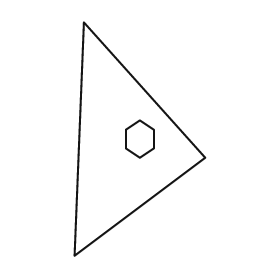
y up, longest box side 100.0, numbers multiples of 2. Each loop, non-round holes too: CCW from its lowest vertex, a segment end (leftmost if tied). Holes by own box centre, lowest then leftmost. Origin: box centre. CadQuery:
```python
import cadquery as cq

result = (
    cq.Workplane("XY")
    .moveTo(-28.0, -50.0)
    .lineTo(28.0, -8.0)
    .lineTo(-24.0, 50.0)
    .close()
    .moveTo(0.0, -8.0)
    .lineTo(6.0, -4.0)
    .lineTo(6.0, 4.0)
    .lineTo(0.0, 8.0)
    .lineTo(-6.0, 4.0)
    .lineTo(-6.0, -4.0)
    .close()
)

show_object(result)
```